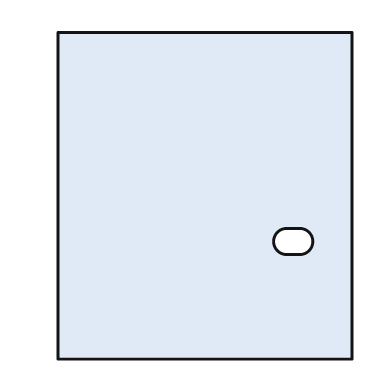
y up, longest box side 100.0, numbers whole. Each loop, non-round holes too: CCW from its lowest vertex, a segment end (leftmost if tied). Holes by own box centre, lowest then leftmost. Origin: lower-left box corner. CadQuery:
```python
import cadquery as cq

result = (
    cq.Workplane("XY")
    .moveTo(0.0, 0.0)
    .lineTo(90.0, 0.0)
    .lineTo(90.0, 100.0)
    .lineTo(0.0, 100.0)
    .close()
    .moveTo(70.0, 32.0)
    .lineTo(74.0, 32.0)
    .threePointArc((78.0, 36.0), (74.0, 40.0))
    .lineTo(70.0, 40.0)
    .threePointArc((66.0, 36.0), (70.0, 32.0))
    .close()
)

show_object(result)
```